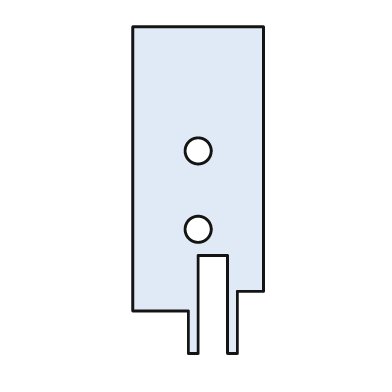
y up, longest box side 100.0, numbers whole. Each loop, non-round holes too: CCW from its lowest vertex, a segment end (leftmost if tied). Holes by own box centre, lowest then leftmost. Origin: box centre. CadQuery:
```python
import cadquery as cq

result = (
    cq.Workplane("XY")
    .moveTo(-3.0, -50.0)
    .lineTo(0.0, -50.0)
    .lineTo(0.0, -20.0)
    .lineTo(9.0, -20.0)
    .lineTo(9.0, -50.0)
    .lineTo(12.0, -50.0)
    .lineTo(12.0, -31.0)
    .lineTo(20.0, -31.0)
    .lineTo(20.0, 50.0)
    .lineTo(-20.0, 50.0)
    .lineTo(-20.0, -37.0)
    .lineTo(-3.0, -37.0)
    .close()
    .moveTo(0.0, -12.0)
    .circle(4.0)
    .moveTo(0.0, 12.0)
    .circle(4.0)
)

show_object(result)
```